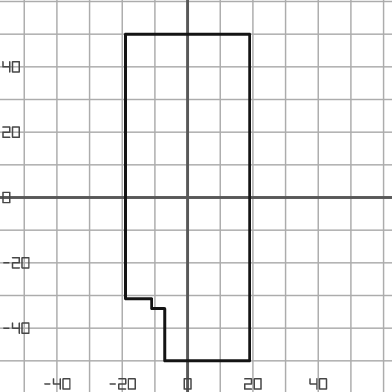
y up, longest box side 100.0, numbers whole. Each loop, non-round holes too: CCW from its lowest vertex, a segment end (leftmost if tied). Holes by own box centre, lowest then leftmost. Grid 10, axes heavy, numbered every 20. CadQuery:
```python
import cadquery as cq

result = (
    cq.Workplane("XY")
    .moveTo(-7.0, -50.0)
    .lineTo(19.0, -50.0)
    .lineTo(19.0, 50.0)
    .lineTo(-19.0, 50.0)
    .lineTo(-19.0, -31.0)
    .lineTo(-11.0, -31.0)
    .lineTo(-11.0, -34.0)
    .lineTo(-7.0, -34.0)
    .close()
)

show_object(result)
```